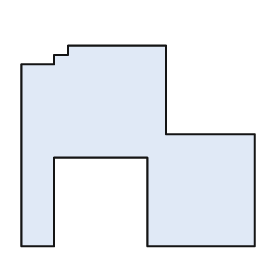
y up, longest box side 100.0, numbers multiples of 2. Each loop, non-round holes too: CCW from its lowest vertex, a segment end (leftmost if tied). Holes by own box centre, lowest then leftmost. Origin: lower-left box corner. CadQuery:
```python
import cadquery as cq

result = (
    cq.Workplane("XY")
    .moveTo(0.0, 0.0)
    .lineTo(14.0, 0.0)
    .lineTo(14.0, 38.0)
    .lineTo(54.0, 38.0)
    .lineTo(54.0, 0.0)
    .lineTo(100.0, 0.0)
    .lineTo(100.0, 48.0)
    .lineTo(62.0, 48.0)
    .lineTo(62.0, 86.0)
    .lineTo(20.0, 86.0)
    .lineTo(20.0, 82.0)
    .lineTo(14.0, 82.0)
    .lineTo(14.0, 78.0)
    .lineTo(0.0, 78.0)
    .close()
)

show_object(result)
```